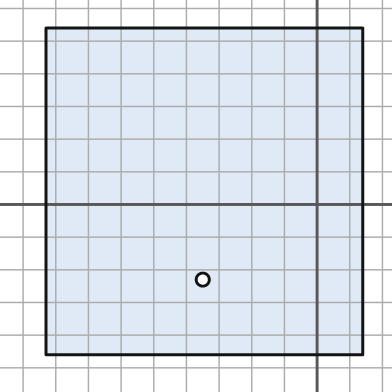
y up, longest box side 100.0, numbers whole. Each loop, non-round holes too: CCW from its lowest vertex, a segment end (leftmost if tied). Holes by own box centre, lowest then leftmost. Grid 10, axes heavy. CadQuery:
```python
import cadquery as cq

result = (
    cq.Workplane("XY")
    .moveTo(-83.0, -46.0)
    .lineTo(14.0, -46.0)
    .lineTo(14.0, 54.0)
    .lineTo(-83.0, 54.0)
    .close()
    .moveTo(-35.0, -23.0)
    .circle(2.0)
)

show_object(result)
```